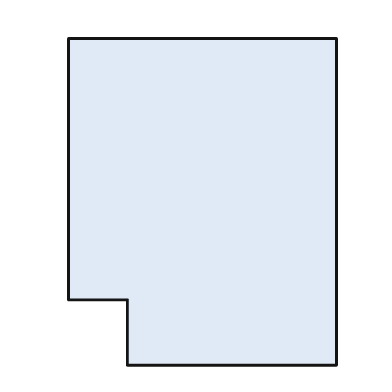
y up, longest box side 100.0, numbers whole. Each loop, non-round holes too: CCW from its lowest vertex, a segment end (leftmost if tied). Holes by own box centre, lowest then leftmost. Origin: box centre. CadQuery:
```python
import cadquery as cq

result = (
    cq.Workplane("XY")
    .moveTo(-23.0, -50.0)
    .lineTo(41.0, -50.0)
    .lineTo(41.0, 50.0)
    .lineTo(-41.0, 50.0)
    .lineTo(-41.0, -30.0)
    .lineTo(-23.0, -30.0)
    .close()
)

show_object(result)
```